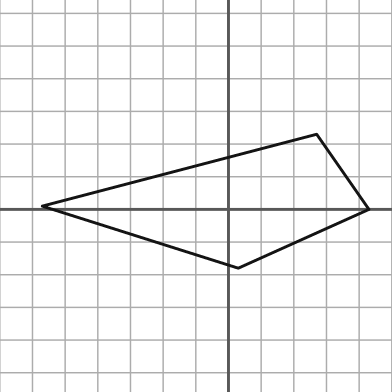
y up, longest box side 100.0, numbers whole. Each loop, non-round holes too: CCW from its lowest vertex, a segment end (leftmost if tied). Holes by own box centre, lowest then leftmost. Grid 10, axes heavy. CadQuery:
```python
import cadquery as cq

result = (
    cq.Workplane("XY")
    .moveTo(3.0, -18.0)
    .lineTo(43.0, 0.0)
    .lineTo(27.0, 23.0)
    .lineTo(-57.0, 1.0)
    .close()
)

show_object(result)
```